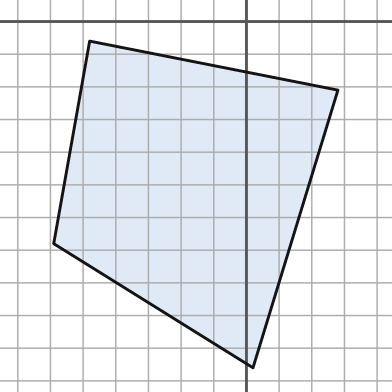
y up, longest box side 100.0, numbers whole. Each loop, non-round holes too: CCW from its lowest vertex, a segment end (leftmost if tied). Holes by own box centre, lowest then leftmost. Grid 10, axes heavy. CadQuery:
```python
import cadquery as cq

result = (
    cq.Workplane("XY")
    .moveTo(2.0, -106.0)
    .lineTo(28.0, -21.0)
    .lineTo(-48.0, -6.0)
    .lineTo(-59.0, -68.0)
    .close()
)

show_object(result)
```